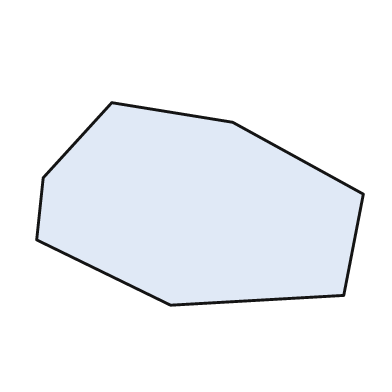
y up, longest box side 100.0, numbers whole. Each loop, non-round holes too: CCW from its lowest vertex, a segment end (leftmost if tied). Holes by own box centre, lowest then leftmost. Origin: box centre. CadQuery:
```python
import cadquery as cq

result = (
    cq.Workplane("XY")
    .moveTo(-9.0, -31.0)
    .lineTo(44.0, -28.0)
    .lineTo(50.0, 3.0)
    .lineTo(10.0, 25.0)
    .lineTo(-27.0, 31.0)
    .lineTo(-48.0, 8.0)
    .lineTo(-50.0, -11.0)
    .close()
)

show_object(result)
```